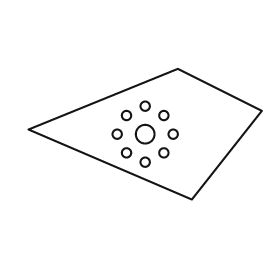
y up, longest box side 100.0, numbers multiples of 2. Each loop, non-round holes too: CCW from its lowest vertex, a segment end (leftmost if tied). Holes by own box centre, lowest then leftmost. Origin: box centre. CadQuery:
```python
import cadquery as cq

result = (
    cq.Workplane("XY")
    .moveTo(20.0, -28.0)
    .lineTo(50.0, 10.0)
    .lineTo(14.0, 28.0)
    .lineTo(-50.0, 2.0)
    .close()
    .moveTo(0.0, -12.0)
    .circle(2.0)
    .moveTo(-8.0, -8.0)
    .circle(2.0)
    .moveTo(8.0, -8.0)
    .circle(2.0)
    .moveTo(-12.0, 0.0)
    .circle(2.0)
    .moveTo(0.0, 0.0)
    .circle(4.0)
    .moveTo(12.0, 0.0)
    .circle(2.0)
    .moveTo(-8.0, 8.0)
    .circle(2.0)
    .moveTo(8.0, 8.0)
    .circle(2.0)
    .moveTo(0.0, 12.0)
    .circle(2.0)
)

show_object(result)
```